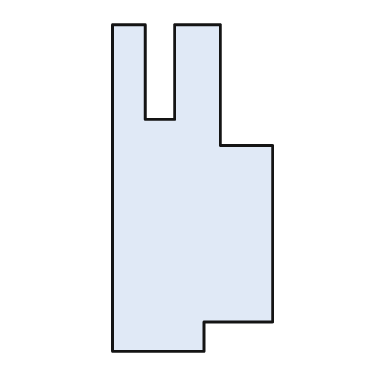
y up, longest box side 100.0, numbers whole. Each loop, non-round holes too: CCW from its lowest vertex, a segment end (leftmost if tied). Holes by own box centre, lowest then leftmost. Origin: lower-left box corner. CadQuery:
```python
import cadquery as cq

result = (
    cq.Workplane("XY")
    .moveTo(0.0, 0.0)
    .lineTo(28.0, 0.0)
    .lineTo(28.0, 9.0)
    .lineTo(49.0, 9.0)
    .lineTo(49.0, 63.0)
    .lineTo(33.0, 63.0)
    .lineTo(33.0, 100.0)
    .lineTo(19.0, 100.0)
    .lineTo(19.0, 71.0)
    .lineTo(10.0, 71.0)
    .lineTo(10.0, 100.0)
    .lineTo(0.0, 100.0)
    .close()
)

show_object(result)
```